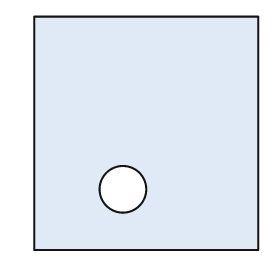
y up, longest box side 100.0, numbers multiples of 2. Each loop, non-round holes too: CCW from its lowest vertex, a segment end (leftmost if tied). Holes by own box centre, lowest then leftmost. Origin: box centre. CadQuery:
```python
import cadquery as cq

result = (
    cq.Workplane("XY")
    .moveTo(-48.0, -50.0)
    .lineTo(48.0, -50.0)
    .lineTo(48.0, 50.0)
    .lineTo(-48.0, 50.0)
    .close()
    .moveTo(-10.0, -24.0)
    .circle(10.0)
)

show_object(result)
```